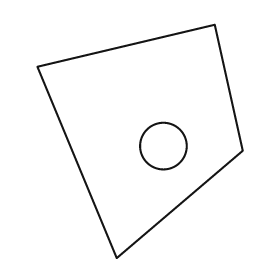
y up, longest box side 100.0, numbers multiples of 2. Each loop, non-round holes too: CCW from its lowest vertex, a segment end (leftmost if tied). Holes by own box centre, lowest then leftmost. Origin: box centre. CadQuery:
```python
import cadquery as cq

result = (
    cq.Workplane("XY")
    .moveTo(-10.0, -50.0)
    .lineTo(44.0, -4.0)
    .lineTo(32.0, 50.0)
    .lineTo(-44.0, 32.0)
    .close()
    .moveTo(10.0, -2.0)
    .circle(10.0)
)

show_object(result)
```